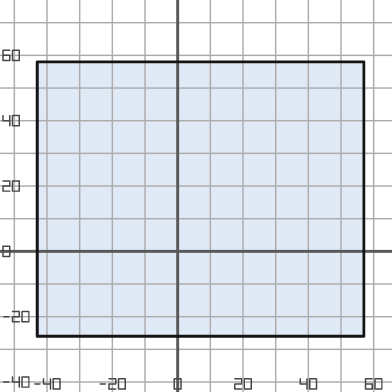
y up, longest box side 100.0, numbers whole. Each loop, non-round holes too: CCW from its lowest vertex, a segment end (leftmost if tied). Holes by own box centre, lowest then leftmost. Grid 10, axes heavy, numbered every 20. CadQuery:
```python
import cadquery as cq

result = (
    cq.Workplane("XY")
    .moveTo(-43.0, -26.0)
    .lineTo(57.0, -26.0)
    .lineTo(57.0, 58.0)
    .lineTo(-43.0, 58.0)
    .close()
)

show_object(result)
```